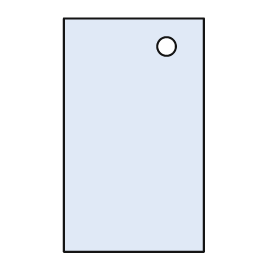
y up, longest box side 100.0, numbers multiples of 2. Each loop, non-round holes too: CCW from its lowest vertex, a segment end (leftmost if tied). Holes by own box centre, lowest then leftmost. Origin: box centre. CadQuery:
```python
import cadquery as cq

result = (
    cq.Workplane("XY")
    .moveTo(-30.0, -50.0)
    .lineTo(30.0, -50.0)
    .lineTo(30.0, 50.0)
    .lineTo(-30.0, 50.0)
    .close()
    .moveTo(14.0, 38.0)
    .circle(4.0)
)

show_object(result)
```